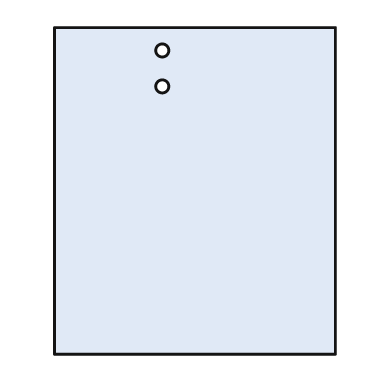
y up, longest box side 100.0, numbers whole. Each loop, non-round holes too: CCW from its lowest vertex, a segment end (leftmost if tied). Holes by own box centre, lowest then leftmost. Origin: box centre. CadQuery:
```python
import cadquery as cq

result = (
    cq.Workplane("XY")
    .moveTo(-43.0, -50.0)
    .lineTo(43.0, -50.0)
    .lineTo(43.0, 50.0)
    .lineTo(-43.0, 50.0)
    .close()
    .moveTo(-10.0, 32.0)
    .circle(2.0)
    .moveTo(-10.0, 43.0)
    .circle(2.0)
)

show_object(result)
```